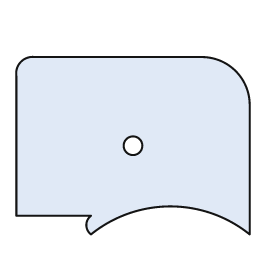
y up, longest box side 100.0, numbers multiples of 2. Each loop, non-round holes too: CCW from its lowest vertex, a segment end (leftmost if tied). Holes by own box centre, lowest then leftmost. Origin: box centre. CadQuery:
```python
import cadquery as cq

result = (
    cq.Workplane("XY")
    .moveTo(-18.0, -38.0)
    .threePointArc((16.0, -26.0), (50.0, -38.0))
    .lineTo(50.0, 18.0)
    .threePointArc((44.0, 32.0), (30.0, 38.0))
    .lineTo(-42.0, 38.0)
    .threePointArc((-48.0, 36.0), (-50.0, 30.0))
    .lineTo(-50.0, -30.0)
    .lineTo(-18.0, -30.0)
    .threePointArc((-20.0, -34.0), (-18.0, -38.0))
    .close()
    .moveTo(0.0, 0.0)
    .circle(4.0)
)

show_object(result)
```